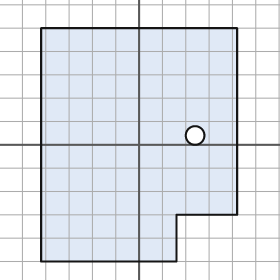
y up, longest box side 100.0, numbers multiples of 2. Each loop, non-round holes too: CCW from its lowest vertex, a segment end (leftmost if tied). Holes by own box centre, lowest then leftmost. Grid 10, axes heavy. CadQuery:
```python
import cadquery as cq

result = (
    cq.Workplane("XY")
    .moveTo(-42.0, -50.0)
    .lineTo(16.0, -50.0)
    .lineTo(16.0, -30.0)
    .lineTo(42.0, -30.0)
    .lineTo(42.0, 50.0)
    .lineTo(-42.0, 50.0)
    .close()
    .moveTo(24.0, 4.0)
    .circle(4.0)
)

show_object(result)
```